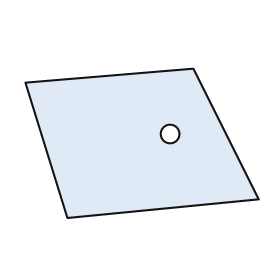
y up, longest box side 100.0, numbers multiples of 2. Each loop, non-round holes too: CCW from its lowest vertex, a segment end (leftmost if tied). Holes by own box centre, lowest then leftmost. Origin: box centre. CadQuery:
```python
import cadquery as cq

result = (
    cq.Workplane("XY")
    .moveTo(-32.0, -32.0)
    .lineTo(50.0, -24.0)
    .lineTo(22.0, 32.0)
    .lineTo(-50.0, 26.0)
    .close()
    .moveTo(12.0, 4.0)
    .circle(4.0)
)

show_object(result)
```